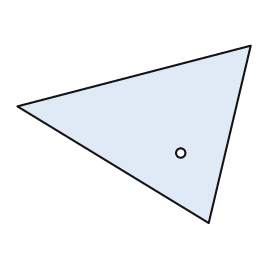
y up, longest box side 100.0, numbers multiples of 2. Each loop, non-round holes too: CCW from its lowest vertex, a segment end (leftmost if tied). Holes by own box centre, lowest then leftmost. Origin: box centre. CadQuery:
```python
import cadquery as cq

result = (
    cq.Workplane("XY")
    .moveTo(32.0, -38.0)
    .lineTo(50.0, 38.0)
    .lineTo(-50.0, 12.0)
    .close()
    .moveTo(20.0, -8.0)
    .circle(2.0)
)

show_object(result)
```